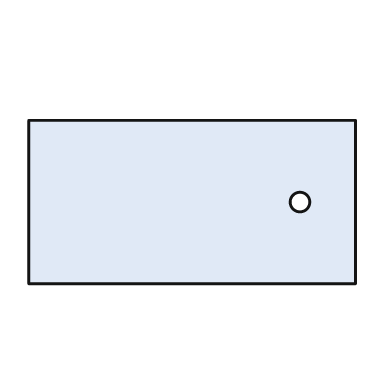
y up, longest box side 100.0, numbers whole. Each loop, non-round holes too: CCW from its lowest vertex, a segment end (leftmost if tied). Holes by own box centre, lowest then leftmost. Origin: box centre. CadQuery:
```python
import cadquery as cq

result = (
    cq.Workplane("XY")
    .moveTo(-50.0, -25.0)
    .lineTo(50.0, -25.0)
    .lineTo(50.0, 25.0)
    .lineTo(-50.0, 25.0)
    .close()
    .moveTo(33.0, 0.0)
    .circle(3.0)
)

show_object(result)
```